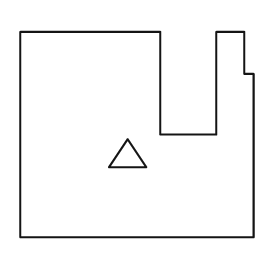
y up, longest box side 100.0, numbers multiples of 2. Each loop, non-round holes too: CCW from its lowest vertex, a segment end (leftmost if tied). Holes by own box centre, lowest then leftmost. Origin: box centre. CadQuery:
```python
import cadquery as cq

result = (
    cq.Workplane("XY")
    .moveTo(-50.0, -44.0)
    .lineTo(50.0, -44.0)
    .lineTo(50.0, 26.0)
    .lineTo(46.0, 26.0)
    .lineTo(46.0, 44.0)
    .lineTo(34.0, 44.0)
    .lineTo(34.0, 0.0)
    .lineTo(10.0, 0.0)
    .lineTo(10.0, 44.0)
    .lineTo(-50.0, 44.0)
    .close()
    .moveTo(-12.0, -14.0)
    .lineTo(4.0, -14.0)
    .lineTo(-4.0, -2.0)
    .close()
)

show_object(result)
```